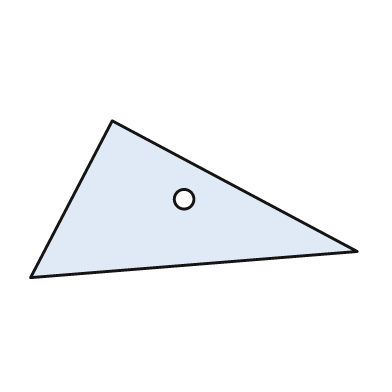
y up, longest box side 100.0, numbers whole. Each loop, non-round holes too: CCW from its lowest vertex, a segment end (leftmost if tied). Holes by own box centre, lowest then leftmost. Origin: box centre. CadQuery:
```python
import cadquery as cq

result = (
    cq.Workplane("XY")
    .moveTo(-50.0, -24.0)
    .lineTo(50.0, -16.0)
    .lineTo(-25.0, 24.0)
    .close()
    .moveTo(-3.0, 0.0)
    .circle(3.0)
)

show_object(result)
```